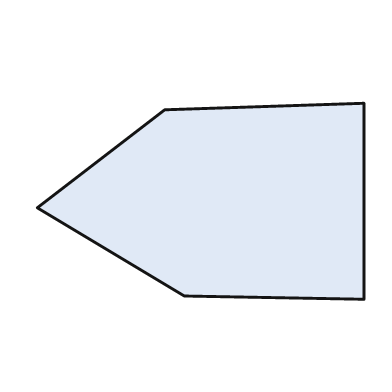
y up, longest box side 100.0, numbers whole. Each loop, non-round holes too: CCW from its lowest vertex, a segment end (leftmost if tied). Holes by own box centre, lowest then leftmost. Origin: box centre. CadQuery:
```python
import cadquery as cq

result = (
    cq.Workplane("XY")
    .moveTo(50.0, -30.0)
    .lineTo(50.0, 30.0)
    .lineTo(-11.0, 28.0)
    .lineTo(-50.0, -2.0)
    .lineTo(-5.0, -29.0)
    .close()
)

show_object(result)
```